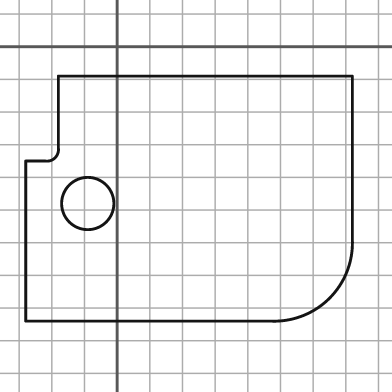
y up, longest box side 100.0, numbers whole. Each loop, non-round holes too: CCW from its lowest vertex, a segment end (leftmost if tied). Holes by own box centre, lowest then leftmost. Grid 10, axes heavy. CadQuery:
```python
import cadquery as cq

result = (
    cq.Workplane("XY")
    .moveTo(-28.0, -84.0)
    .lineTo(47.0, -84.0)
    .threePointArc((65.0, -77.0), (72.0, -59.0))
    .lineTo(72.0, -9.0)
    .lineTo(-18.0, -9.0)
    .lineTo(-18.0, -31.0)
    .threePointArc((-19.0, -34.0), (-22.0, -35.0))
    .lineTo(-28.0, -35.0)
    .close()
    .moveTo(-9.0, -48.0)
    .circle(8.0)
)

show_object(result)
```